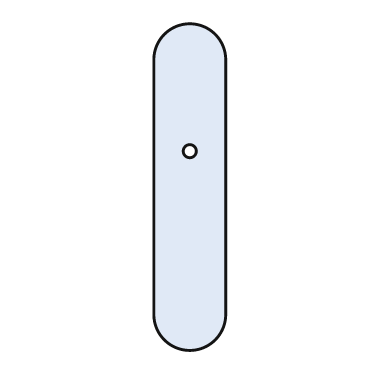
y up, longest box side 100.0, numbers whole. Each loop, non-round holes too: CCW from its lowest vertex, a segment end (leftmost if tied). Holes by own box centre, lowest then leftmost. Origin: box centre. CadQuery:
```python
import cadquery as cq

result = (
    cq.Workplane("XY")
    .moveTo(-11.0, -39.0)
    .threePointArc((0.0, -50.0), (11.0, -39.0))
    .lineTo(11.0, 39.0)
    .threePointArc((0.0, 50.0), (-11.0, 39.0))
    .close()
    .moveTo(0.0, 11.0)
    .circle(2.0)
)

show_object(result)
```